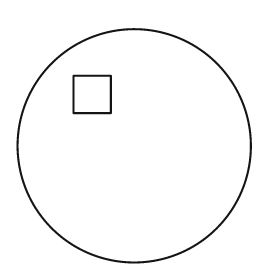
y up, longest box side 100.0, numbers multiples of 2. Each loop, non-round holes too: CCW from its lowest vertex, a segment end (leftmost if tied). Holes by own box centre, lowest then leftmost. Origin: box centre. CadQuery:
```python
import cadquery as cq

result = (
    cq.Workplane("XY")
    .moveTo(0.0, 0.0)
    .circle(50.0)
    .moveTo(-26.0, 14.0)
    .lineTo(-10.0, 14.0)
    .lineTo(-10.0, 30.0)
    .lineTo(-26.0, 30.0)
    .close()
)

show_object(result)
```